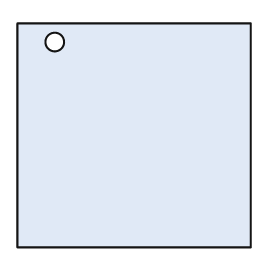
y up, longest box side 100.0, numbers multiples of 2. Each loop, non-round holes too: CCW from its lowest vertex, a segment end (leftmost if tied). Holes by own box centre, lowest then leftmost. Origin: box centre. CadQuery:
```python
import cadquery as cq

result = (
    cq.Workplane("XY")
    .moveTo(-50.0, -48.0)
    .lineTo(50.0, -48.0)
    .lineTo(50.0, 48.0)
    .lineTo(-50.0, 48.0)
    .close()
    .moveTo(-34.0, 40.0)
    .circle(4.0)
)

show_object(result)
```